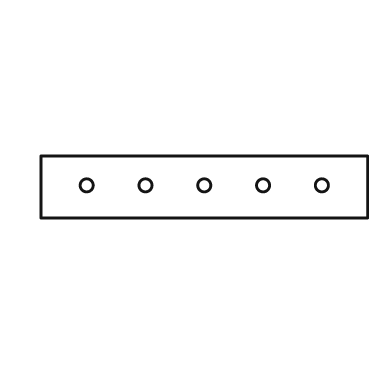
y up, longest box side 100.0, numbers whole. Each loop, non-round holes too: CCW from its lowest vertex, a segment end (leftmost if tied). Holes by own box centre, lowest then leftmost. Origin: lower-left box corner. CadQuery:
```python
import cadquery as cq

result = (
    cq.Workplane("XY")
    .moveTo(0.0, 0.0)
    .lineTo(100.0, 0.0)
    .lineTo(100.0, 19.0)
    .lineTo(0.0, 19.0)
    .close()
    .moveTo(14.0, 10.0)
    .circle(2.0)
    .moveTo(32.0, 10.0)
    .circle(2.0)
    .moveTo(50.0, 10.0)
    .circle(2.0)
    .moveTo(68.0, 10.0)
    .circle(2.0)
    .moveTo(86.0, 10.0)
    .circle(2.0)
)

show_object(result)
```